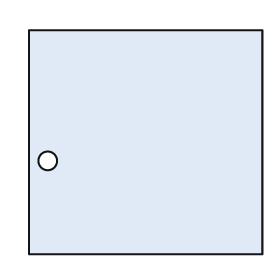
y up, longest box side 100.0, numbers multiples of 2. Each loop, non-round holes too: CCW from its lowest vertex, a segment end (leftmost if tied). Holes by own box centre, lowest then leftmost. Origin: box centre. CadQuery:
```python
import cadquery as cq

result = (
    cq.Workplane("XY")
    .moveTo(-50.0, -48.0)
    .lineTo(50.0, -48.0)
    .lineTo(50.0, 48.0)
    .lineTo(-50.0, 48.0)
    .close()
    .moveTo(-42.0, -8.0)
    .circle(4.0)
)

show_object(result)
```